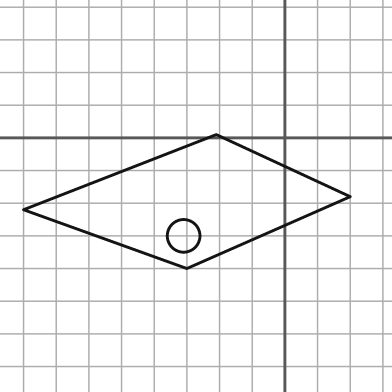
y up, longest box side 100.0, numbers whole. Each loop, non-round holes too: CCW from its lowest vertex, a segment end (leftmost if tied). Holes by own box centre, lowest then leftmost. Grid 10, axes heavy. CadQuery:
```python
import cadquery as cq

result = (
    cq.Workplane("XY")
    .moveTo(-30.0, -40.0)
    .lineTo(20.0, -18.0)
    .lineTo(-21.0, 1.0)
    .lineTo(-80.0, -22.0)
    .close()
    .moveTo(-31.0, -30.0)
    .circle(5.0)
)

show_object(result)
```